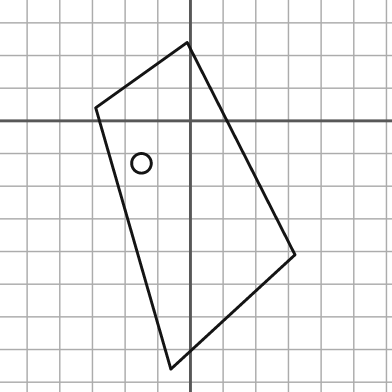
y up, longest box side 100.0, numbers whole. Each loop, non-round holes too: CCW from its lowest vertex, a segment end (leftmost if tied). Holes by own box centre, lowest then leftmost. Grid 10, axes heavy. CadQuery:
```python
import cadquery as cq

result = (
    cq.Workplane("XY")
    .moveTo(-6.0, -76.0)
    .lineTo(32.0, -41.0)
    .lineTo(-1.0, 24.0)
    .lineTo(-29.0, 4.0)
    .close()
    .moveTo(-15.0, -13.0)
    .circle(3.0)
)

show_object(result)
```